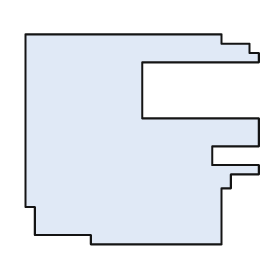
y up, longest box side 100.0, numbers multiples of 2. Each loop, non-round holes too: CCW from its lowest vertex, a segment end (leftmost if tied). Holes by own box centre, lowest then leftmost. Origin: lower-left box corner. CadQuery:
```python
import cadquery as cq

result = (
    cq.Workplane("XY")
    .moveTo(28.0, 0.0)
    .lineTo(84.0, 0.0)
    .lineTo(84.0, 24.0)
    .lineTo(88.0, 24.0)
    .lineTo(88.0, 30.0)
    .lineTo(100.0, 30.0)
    .lineTo(100.0, 34.0)
    .lineTo(80.0, 34.0)
    .lineTo(80.0, 42.0)
    .lineTo(100.0, 42.0)
    .lineTo(100.0, 54.0)
    .lineTo(50.0, 54.0)
    .lineTo(50.0, 78.0)
    .lineTo(100.0, 78.0)
    .lineTo(100.0, 82.0)
    .lineTo(96.0, 82.0)
    .lineTo(96.0, 86.0)
    .lineTo(84.0, 86.0)
    .lineTo(84.0, 90.0)
    .lineTo(0.0, 90.0)
    .lineTo(0.0, 16.0)
    .lineTo(4.0, 16.0)
    .lineTo(4.0, 4.0)
    .lineTo(28.0, 4.0)
    .close()
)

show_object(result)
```